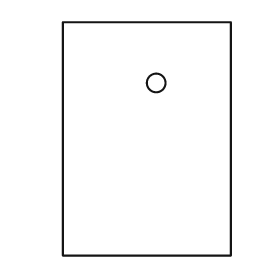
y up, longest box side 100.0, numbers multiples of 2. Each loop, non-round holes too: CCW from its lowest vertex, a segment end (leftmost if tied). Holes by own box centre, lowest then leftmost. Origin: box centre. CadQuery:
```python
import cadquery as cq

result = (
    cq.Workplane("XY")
    .moveTo(-36.0, -50.0)
    .lineTo(36.0, -50.0)
    .lineTo(36.0, 50.0)
    .lineTo(-36.0, 50.0)
    .close()
    .moveTo(4.0, 24.0)
    .circle(4.0)
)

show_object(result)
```